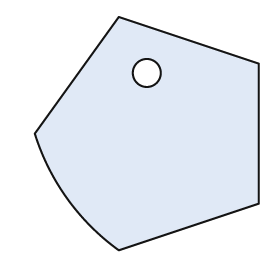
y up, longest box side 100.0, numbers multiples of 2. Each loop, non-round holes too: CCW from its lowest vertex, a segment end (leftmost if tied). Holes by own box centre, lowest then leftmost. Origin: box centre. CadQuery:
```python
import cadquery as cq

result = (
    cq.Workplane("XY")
    .moveTo(-12.0, -50.0)
    .lineTo(48.0, -30.0)
    .lineTo(48.0, 30.0)
    .lineTo(-12.0, 50.0)
    .lineTo(-48.0, 0.0)
    .threePointArc((-34.0, -28.0), (-12.0, -50.0))
    .close()
    .moveTo(0.0, 26.0)
    .circle(6.0)
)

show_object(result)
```